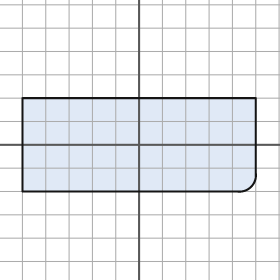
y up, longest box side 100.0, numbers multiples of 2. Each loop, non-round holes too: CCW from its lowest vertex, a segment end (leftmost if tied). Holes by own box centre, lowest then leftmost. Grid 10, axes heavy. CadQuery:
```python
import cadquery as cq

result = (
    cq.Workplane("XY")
    .moveTo(-50.0, -20.0)
    .lineTo(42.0, -20.0)
    .threePointArc((48.0, -18.0), (50.0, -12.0))
    .lineTo(50.0, 20.0)
    .lineTo(-50.0, 20.0)
    .close()
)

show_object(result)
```